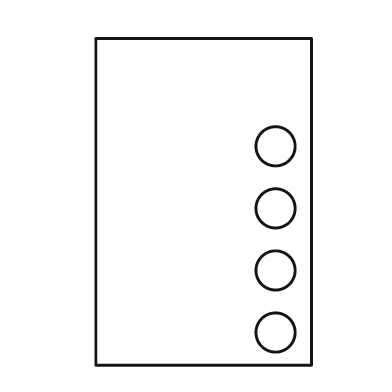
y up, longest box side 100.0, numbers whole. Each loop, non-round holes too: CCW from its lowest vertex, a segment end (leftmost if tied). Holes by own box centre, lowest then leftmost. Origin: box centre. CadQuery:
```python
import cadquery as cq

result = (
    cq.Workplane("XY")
    .moveTo(-33.0, -50.0)
    .lineTo(33.0, -50.0)
    .lineTo(33.0, 50.0)
    .lineTo(-33.0, 50.0)
    .close()
    .moveTo(22.0, -40.0)
    .circle(6.0)
    .moveTo(22.0, -21.0)
    .circle(6.0)
    .moveTo(22.0, -2.0)
    .circle(6.0)
    .moveTo(22.0, 17.0)
    .circle(6.0)
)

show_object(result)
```